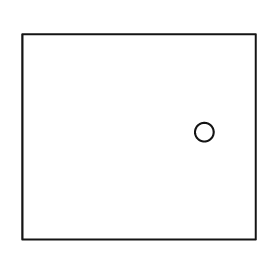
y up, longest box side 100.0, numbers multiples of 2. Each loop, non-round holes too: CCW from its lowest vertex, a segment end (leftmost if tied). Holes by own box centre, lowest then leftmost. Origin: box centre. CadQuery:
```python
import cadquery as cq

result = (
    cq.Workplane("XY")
    .moveTo(-50.0, -44.0)
    .lineTo(50.0, -44.0)
    .lineTo(50.0, 44.0)
    .lineTo(-50.0, 44.0)
    .close()
    .moveTo(28.0, 2.0)
    .circle(4.0)
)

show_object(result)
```